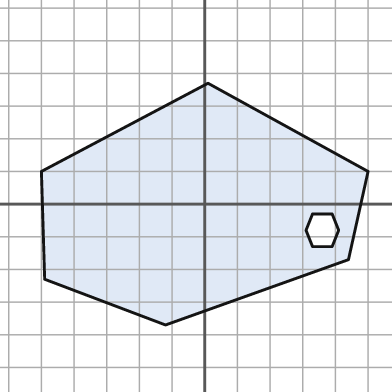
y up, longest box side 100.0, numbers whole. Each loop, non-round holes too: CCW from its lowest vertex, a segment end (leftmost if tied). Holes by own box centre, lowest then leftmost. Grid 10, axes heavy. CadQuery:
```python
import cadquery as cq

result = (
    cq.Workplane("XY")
    .moveTo(-12.0, -37.0)
    .lineTo(44.0, -17.0)
    .lineTo(50.0, 10.0)
    .lineTo(1.0, 37.0)
    .lineTo(-50.0, 10.0)
    .lineTo(-49.0, -23.0)
    .close()
    .moveTo(33.0, -13.0)
    .lineTo(39.0, -13.0)
    .lineTo(41.0, -8.0)
    .lineTo(39.0, -3.0)
    .lineTo(33.0, -3.0)
    .lineTo(31.0, -8.0)
    .close()
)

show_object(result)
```